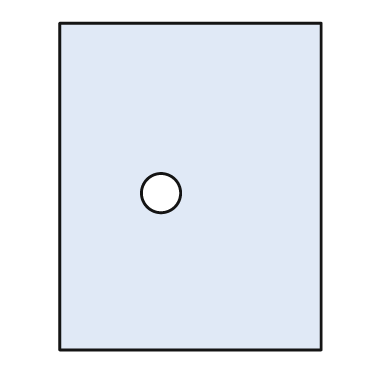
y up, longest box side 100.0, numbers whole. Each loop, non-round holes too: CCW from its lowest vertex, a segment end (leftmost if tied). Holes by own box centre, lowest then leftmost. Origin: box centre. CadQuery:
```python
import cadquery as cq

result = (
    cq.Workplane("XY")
    .moveTo(-40.0, -50.0)
    .lineTo(40.0, -50.0)
    .lineTo(40.0, 50.0)
    .lineTo(-40.0, 50.0)
    .close()
    .moveTo(-9.0, -2.0)
    .circle(6.0)
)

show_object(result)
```